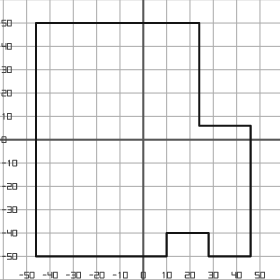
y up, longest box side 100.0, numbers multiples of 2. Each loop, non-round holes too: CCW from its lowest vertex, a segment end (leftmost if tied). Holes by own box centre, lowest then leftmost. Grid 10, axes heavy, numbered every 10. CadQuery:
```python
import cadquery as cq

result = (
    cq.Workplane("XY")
    .moveTo(-46.0, -50.0)
    .lineTo(10.0, -50.0)
    .lineTo(10.0, -40.0)
    .lineTo(28.0, -40.0)
    .lineTo(28.0, -50.0)
    .lineTo(46.0, -50.0)
    .lineTo(46.0, 6.0)
    .lineTo(24.0, 6.0)
    .lineTo(24.0, 50.0)
    .lineTo(-46.0, 50.0)
    .close()
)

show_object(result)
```